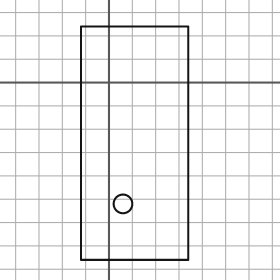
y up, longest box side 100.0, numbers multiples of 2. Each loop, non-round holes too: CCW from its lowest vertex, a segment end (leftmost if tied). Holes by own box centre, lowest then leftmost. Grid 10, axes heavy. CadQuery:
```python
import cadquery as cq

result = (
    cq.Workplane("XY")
    .moveTo(-12.0, -76.0)
    .lineTo(34.0, -76.0)
    .lineTo(34.0, 24.0)
    .lineTo(-12.0, 24.0)
    .close()
    .moveTo(6.0, -52.0)
    .circle(4.0)
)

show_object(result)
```